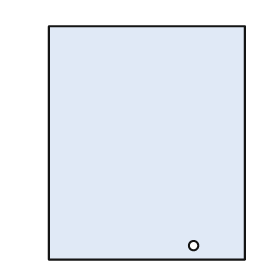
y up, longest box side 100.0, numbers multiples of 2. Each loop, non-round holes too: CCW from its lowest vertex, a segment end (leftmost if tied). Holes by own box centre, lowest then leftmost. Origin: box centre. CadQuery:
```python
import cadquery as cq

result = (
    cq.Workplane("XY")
    .moveTo(-42.0, -50.0)
    .lineTo(42.0, -50.0)
    .lineTo(42.0, 50.0)
    .lineTo(-42.0, 50.0)
    .close()
    .moveTo(20.0, -44.0)
    .circle(2.0)
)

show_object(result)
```